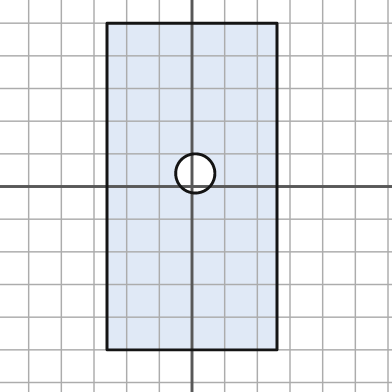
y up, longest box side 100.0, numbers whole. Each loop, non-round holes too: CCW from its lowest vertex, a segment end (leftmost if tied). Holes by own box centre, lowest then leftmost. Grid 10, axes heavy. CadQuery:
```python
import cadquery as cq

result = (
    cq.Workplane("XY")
    .moveTo(-26.0, -50.0)
    .lineTo(26.0, -50.0)
    .lineTo(26.0, 50.0)
    .lineTo(-26.0, 50.0)
    .close()
    .moveTo(1.0, 4.0)
    .circle(6.0)
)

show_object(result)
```